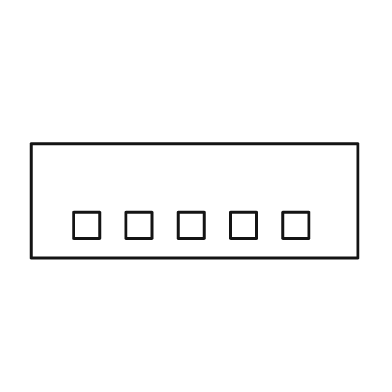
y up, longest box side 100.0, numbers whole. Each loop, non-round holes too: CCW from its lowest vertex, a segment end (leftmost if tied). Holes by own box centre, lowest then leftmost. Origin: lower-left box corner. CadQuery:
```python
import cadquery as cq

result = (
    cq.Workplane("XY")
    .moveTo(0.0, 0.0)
    .lineTo(100.0, 0.0)
    .lineTo(100.0, 35.0)
    .lineTo(0.0, 35.0)
    .close()
    .moveTo(13.0, 6.0)
    .lineTo(21.0, 6.0)
    .lineTo(21.0, 14.0)
    .lineTo(13.0, 14.0)
    .close()
    .moveTo(29.0, 6.0)
    .lineTo(37.0, 6.0)
    .lineTo(37.0, 14.0)
    .lineTo(29.0, 14.0)
    .close()
    .moveTo(45.0, 6.0)
    .lineTo(53.0, 6.0)
    .lineTo(53.0, 14.0)
    .lineTo(45.0, 14.0)
    .close()
    .moveTo(61.0, 6.0)
    .lineTo(69.0, 6.0)
    .lineTo(69.0, 14.0)
    .lineTo(61.0, 14.0)
    .close()
    .moveTo(77.0, 6.0)
    .lineTo(85.0, 6.0)
    .lineTo(85.0, 14.0)
    .lineTo(77.0, 14.0)
    .close()
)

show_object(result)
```